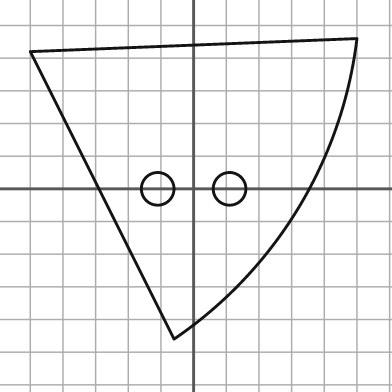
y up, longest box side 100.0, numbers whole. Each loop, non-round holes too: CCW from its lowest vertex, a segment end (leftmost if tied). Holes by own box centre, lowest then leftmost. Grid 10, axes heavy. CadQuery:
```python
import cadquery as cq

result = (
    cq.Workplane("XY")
    .moveTo(-6.0, -46.0)
    .threePointArc((32.0, -6.0), (50.0, 46.0))
    .lineTo(-50.0, 42.0)
    .close()
    .moveTo(-11.0, 0.0)
    .circle(5.0)
    .moveTo(11.0, 0.0)
    .circle(5.0)
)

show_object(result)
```